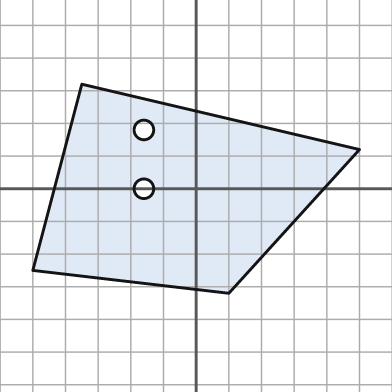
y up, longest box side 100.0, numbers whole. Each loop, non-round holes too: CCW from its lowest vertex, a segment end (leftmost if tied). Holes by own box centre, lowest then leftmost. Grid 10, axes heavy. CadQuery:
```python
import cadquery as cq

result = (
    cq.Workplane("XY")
    .moveTo(10.0, -32.0)
    .lineTo(50.0, 12.0)
    .lineTo(-35.0, 32.0)
    .lineTo(-50.0, -25.0)
    .close()
    .moveTo(-16.0, 0.0)
    .circle(3.0)
    .moveTo(-16.0, 18.0)
    .circle(3.0)
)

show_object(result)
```